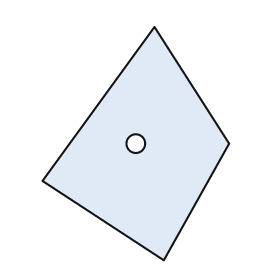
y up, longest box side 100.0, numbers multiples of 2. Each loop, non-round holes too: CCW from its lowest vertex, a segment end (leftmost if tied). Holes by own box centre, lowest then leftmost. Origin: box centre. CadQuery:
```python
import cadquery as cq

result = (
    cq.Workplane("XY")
    .moveTo(12.0, -50.0)
    .lineTo(40.0, 0.0)
    .lineTo(8.0, 50.0)
    .lineTo(-40.0, -16.0)
    .close()
    .moveTo(0.0, 0.0)
    .circle(4.0)
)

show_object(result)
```